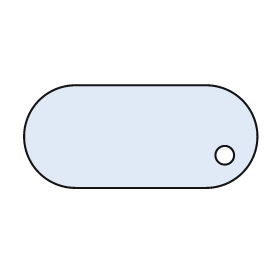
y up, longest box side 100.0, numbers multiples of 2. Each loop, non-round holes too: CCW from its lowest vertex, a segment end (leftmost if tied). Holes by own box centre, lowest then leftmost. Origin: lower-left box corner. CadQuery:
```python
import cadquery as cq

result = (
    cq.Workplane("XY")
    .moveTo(22.0, 0.0)
    .lineTo(78.0, 0.0)
    .threePointArc((100.0, 22.0), (78.0, 44.0))
    .lineTo(22.0, 44.0)
    .threePointArc((0.0, 22.0), (22.0, 0.0))
    .close()
    .moveTo(86.0, 14.0)
    .circle(4.0)
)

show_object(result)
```